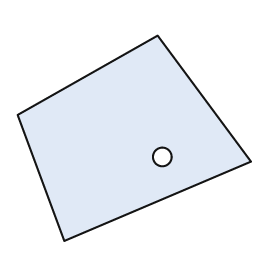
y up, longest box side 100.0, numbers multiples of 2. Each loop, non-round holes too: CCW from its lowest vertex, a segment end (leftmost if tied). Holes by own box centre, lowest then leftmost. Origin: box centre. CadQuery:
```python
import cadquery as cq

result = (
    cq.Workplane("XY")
    .moveTo(-30.0, -44.0)
    .lineTo(50.0, -10.0)
    .lineTo(10.0, 44.0)
    .lineTo(-50.0, 10.0)
    .close()
    .moveTo(12.0, -8.0)
    .circle(4.0)
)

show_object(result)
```